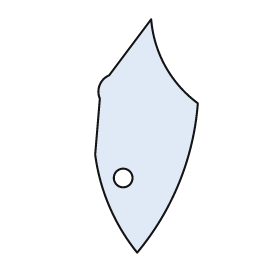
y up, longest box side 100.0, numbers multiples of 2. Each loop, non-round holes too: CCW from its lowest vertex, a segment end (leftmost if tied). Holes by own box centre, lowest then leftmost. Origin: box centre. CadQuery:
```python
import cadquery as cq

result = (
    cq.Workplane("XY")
    .moveTo(-4.0, -50.0)
    .threePointArc((14.0, -20.0), (22.0, 14.0))
    .threePointArc((8.0, 30.0), (2.0, 50.0))
    .lineTo(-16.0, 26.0)
    .threePointArc((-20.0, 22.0), (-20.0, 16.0))
    .lineTo(-22.0, -8.0)
    .threePointArc((-16.0, -30.0), (-4.0, -50.0))
    .close()
    .moveTo(-10.0, -18.0)
    .circle(4.0)
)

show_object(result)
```